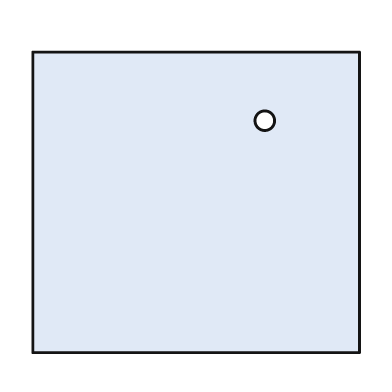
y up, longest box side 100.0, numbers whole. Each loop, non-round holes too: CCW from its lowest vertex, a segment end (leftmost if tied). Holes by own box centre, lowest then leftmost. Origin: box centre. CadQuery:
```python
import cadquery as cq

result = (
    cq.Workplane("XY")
    .moveTo(-50.0, -46.0)
    .lineTo(50.0, -46.0)
    .lineTo(50.0, 46.0)
    .lineTo(-50.0, 46.0)
    .close()
    .moveTo(21.0, 25.0)
    .circle(3.0)
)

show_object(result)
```